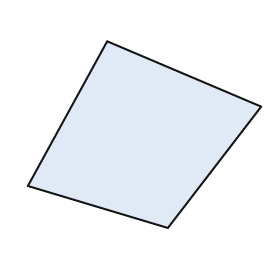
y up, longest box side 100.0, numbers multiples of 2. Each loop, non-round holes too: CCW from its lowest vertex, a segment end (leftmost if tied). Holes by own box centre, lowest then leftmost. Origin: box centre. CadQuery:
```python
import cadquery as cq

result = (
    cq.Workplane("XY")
    .moveTo(10.0, -40.0)
    .lineTo(50.0, 12.0)
    .lineTo(-16.0, 40.0)
    .lineTo(-50.0, -22.0)
    .close()
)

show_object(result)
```